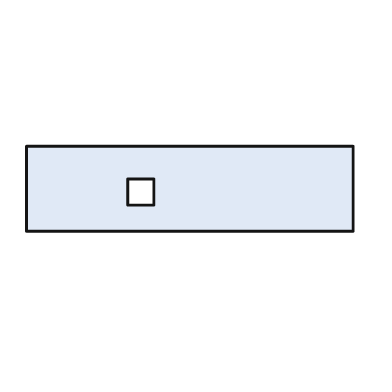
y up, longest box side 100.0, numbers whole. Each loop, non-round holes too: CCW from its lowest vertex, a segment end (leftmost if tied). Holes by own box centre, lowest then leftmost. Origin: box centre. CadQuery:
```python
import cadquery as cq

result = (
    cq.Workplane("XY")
    .moveTo(-50.0, -13.0)
    .lineTo(50.0, -13.0)
    .lineTo(50.0, 13.0)
    .lineTo(-50.0, 13.0)
    .close()
    .moveTo(-19.0, -5.0)
    .lineTo(-11.0, -5.0)
    .lineTo(-11.0, 3.0)
    .lineTo(-19.0, 3.0)
    .close()
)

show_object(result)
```